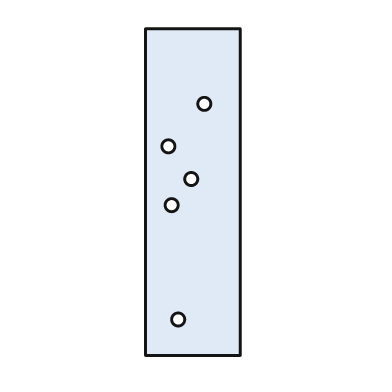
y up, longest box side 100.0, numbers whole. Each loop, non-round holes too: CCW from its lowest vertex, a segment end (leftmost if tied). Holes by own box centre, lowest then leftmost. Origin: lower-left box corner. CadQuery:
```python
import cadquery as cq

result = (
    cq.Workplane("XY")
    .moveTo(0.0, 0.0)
    .lineTo(29.0, 0.0)
    .lineTo(29.0, 100.0)
    .lineTo(0.0, 100.0)
    .close()
    .moveTo(10.0, 11.0)
    .circle(2.0)
    .moveTo(8.0, 46.0)
    .circle(2.0)
    .moveTo(14.0, 54.0)
    .circle(2.0)
    .moveTo(7.0, 64.0)
    .circle(2.0)
    .moveTo(18.0, 77.0)
    .circle(2.0)
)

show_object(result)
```